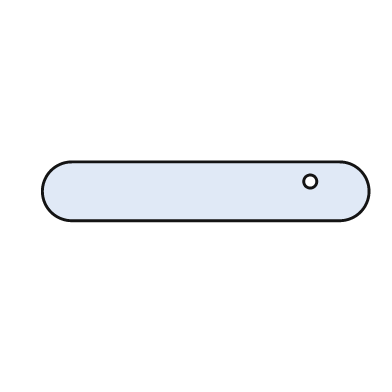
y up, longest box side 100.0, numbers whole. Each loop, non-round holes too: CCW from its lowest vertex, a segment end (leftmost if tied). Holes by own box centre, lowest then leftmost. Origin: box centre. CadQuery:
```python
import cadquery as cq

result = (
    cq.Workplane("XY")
    .moveTo(-41.0, -9.0)
    .lineTo(41.0, -9.0)
    .threePointArc((50.0, 0.0), (41.0, 9.0))
    .lineTo(-41.0, 9.0)
    .threePointArc((-50.0, 0.0), (-41.0, -9.0))
    .close()
    .moveTo(32.0, 3.0)
    .circle(2.0)
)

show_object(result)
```